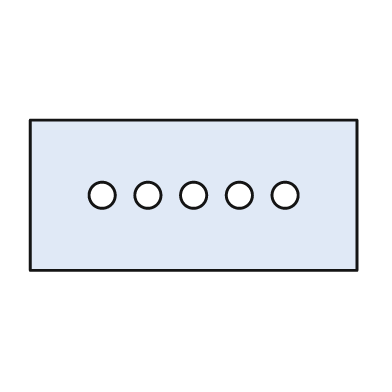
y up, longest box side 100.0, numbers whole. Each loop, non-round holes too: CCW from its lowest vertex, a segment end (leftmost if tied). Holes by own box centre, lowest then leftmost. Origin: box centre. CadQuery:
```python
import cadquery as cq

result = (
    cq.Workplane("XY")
    .moveTo(-50.0, -23.0)
    .lineTo(50.0, -23.0)
    .lineTo(50.0, 23.0)
    .lineTo(-50.0, 23.0)
    .close()
    .moveTo(-28.0, 0.0)
    .circle(4.0)
    .moveTo(-14.0, 0.0)
    .circle(4.0)
    .moveTo(0.0, 0.0)
    .circle(4.0)
    .moveTo(14.0, 0.0)
    .circle(4.0)
    .moveTo(28.0, 0.0)
    .circle(4.0)
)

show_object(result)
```